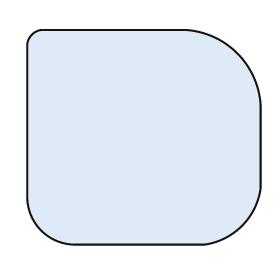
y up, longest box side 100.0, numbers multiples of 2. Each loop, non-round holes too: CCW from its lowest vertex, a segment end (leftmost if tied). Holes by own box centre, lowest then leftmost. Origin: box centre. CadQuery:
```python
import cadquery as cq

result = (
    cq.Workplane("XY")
    .moveTo(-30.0, -46.0)
    .lineTo(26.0, -46.0)
    .threePointArc((42.0, -38.0), (50.0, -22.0))
    .lineTo(50.0, 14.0)
    .threePointArc((40.0, 36.0), (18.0, 46.0))
    .lineTo(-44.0, 46.0)
    .threePointArc((-48.0, 44.0), (-50.0, 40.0))
    .lineTo(-50.0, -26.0)
    .threePointArc((-44.0, -40.0), (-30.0, -46.0))
    .close()
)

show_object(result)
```